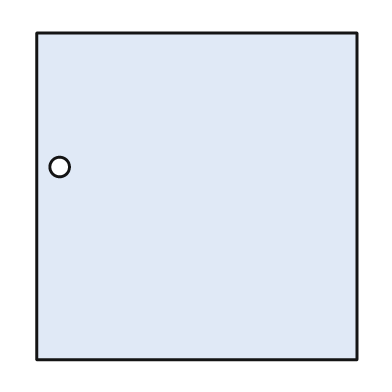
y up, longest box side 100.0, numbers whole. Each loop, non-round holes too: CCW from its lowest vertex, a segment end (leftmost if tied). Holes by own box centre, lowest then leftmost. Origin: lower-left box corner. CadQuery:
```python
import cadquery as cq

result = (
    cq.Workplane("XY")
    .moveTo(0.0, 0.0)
    .lineTo(98.0, 0.0)
    .lineTo(98.0, 100.0)
    .lineTo(0.0, 100.0)
    .close()
    .moveTo(7.0, 59.0)
    .circle(3.0)
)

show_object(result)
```